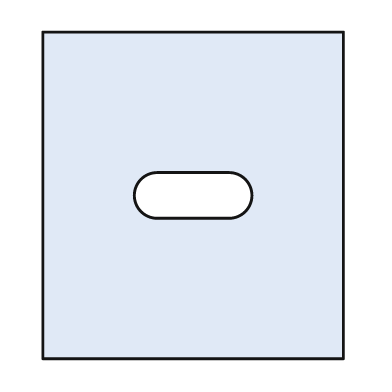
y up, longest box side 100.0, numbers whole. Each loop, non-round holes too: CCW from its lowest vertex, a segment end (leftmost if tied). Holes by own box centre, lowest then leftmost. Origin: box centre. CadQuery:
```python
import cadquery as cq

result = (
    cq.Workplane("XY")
    .moveTo(-46.0, -50.0)
    .lineTo(46.0, -50.0)
    .lineTo(46.0, 50.0)
    .lineTo(-46.0, 50.0)
    .close()
    .moveTo(-11.0, -7.0)
    .lineTo(11.0, -7.0)
    .threePointArc((18.0, 0.0), (11.0, 7.0))
    .lineTo(-11.0, 7.0)
    .threePointArc((-18.0, 0.0), (-11.0, -7.0))
    .close()
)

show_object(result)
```